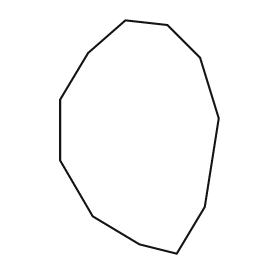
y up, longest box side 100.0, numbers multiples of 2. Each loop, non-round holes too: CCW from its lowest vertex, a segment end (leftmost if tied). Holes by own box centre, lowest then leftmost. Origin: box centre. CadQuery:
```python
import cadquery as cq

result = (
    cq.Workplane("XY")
    .moveTo(16.0, -50.0)
    .lineTo(28.0, -30.0)
    .lineTo(34.0, 8.0)
    .lineTo(26.0, 34.0)
    .lineTo(12.0, 48.0)
    .lineTo(-6.0, 50.0)
    .lineTo(-22.0, 36.0)
    .lineTo(-34.0, 16.0)
    .lineTo(-34.0, -10.0)
    .lineTo(-20.0, -34.0)
    .lineTo(0.0, -46.0)
    .close()
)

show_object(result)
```